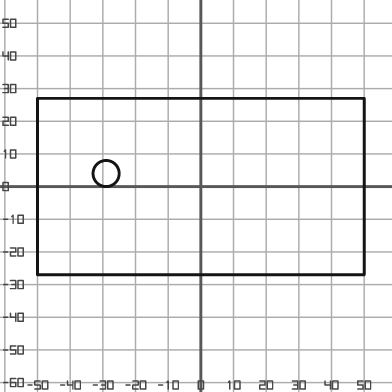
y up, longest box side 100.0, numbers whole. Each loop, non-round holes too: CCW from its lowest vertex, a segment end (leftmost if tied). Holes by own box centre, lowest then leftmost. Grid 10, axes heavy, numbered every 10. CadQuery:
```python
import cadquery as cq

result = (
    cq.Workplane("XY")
    .moveTo(-50.0, -27.0)
    .lineTo(50.0, -27.0)
    .lineTo(50.0, 27.0)
    .lineTo(-50.0, 27.0)
    .close()
    .moveTo(-29.0, 4.0)
    .circle(4.0)
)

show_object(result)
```